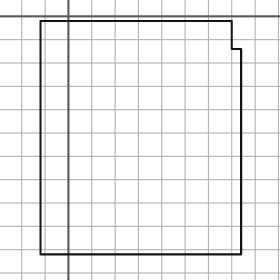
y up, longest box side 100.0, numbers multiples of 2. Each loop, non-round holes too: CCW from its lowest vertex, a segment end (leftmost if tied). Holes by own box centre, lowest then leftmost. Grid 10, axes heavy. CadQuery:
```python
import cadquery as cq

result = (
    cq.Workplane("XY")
    .moveTo(-12.0, -102.0)
    .lineTo(74.0, -102.0)
    .lineTo(74.0, -14.0)
    .lineTo(70.0, -14.0)
    .lineTo(70.0, -2.0)
    .lineTo(-12.0, -2.0)
    .close()
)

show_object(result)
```